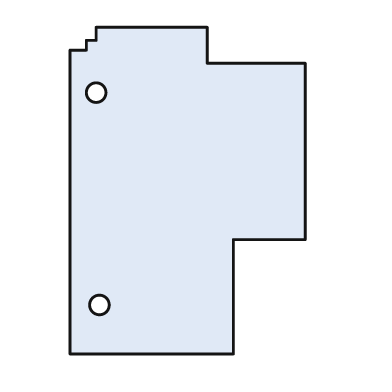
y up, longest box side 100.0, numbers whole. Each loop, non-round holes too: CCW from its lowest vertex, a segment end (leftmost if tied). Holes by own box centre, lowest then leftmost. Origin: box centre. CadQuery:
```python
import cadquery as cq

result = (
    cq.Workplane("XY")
    .moveTo(-36.0, -50.0)
    .lineTo(14.0, -50.0)
    .lineTo(14.0, -15.0)
    .lineTo(36.0, -15.0)
    .lineTo(36.0, 39.0)
    .lineTo(6.0, 39.0)
    .lineTo(6.0, 50.0)
    .lineTo(-28.0, 50.0)
    .lineTo(-28.0, 46.0)
    .lineTo(-31.0, 46.0)
    .lineTo(-31.0, 43.0)
    .lineTo(-36.0, 43.0)
    .close()
    .moveTo(-27.0, -35.0)
    .circle(3.0)
    .moveTo(-28.0, 30.0)
    .circle(3.0)
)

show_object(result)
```